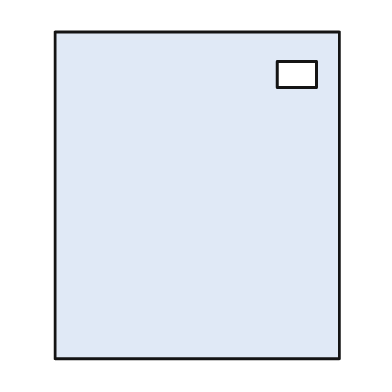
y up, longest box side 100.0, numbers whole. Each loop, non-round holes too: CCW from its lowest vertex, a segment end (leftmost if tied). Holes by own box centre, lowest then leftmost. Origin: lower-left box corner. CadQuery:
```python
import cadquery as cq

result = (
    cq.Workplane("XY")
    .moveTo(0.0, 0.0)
    .lineTo(87.0, 0.0)
    .lineTo(87.0, 100.0)
    .lineTo(0.0, 100.0)
    .close()
    .moveTo(68.0, 83.0)
    .lineTo(80.0, 83.0)
    .lineTo(80.0, 91.0)
    .lineTo(68.0, 91.0)
    .close()
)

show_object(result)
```